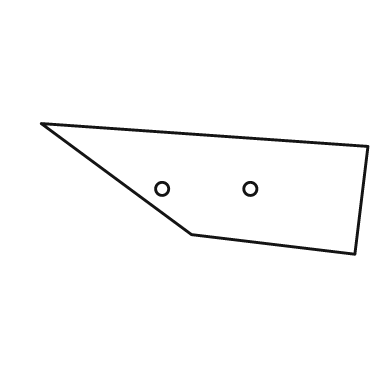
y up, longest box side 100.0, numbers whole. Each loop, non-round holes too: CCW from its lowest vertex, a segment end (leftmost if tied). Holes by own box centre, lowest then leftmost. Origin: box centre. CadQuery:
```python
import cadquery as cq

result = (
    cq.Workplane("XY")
    .moveTo(46.0, -20.0)
    .lineTo(50.0, 13.0)
    .lineTo(-50.0, 20.0)
    .lineTo(-4.0, -14.0)
    .close()
    .moveTo(-13.0, 0.0)
    .circle(2.0)
    .moveTo(14.0, 0.0)
    .circle(2.0)
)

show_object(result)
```